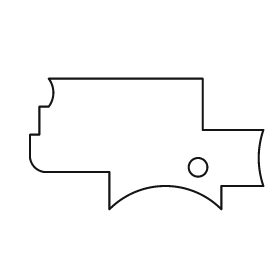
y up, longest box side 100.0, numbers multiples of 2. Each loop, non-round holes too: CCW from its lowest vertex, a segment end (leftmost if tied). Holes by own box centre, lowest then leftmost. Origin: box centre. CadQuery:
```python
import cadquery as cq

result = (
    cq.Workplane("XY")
    .moveTo(-16.0, -28.0)
    .threePointArc((8.0, -18.0), (32.0, -28.0))
    .lineTo(32.0, -18.0)
    .lineTo(50.0, -18.0)
    .threePointArc((48.0, -6.0), (50.0, 6.0))
    .lineTo(24.0, 6.0)
    .lineTo(24.0, 28.0)
    .lineTo(-42.0, 28.0)
    .threePointArc((-40.0, 22.0), (-42.0, 16.0))
    .lineTo(-46.0, 16.0)
    .lineTo(-46.0, 4.0)
    .lineTo(-50.0, 4.0)
    .lineTo(-50.0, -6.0)
    .threePointArc((-48.0, -10.0), (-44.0, -12.0))
    .lineTo(-16.0, -12.0)
    .close()
    .moveTo(22.0, -10.0)
    .circle(4.0)
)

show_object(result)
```